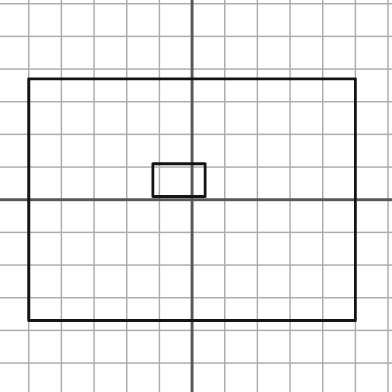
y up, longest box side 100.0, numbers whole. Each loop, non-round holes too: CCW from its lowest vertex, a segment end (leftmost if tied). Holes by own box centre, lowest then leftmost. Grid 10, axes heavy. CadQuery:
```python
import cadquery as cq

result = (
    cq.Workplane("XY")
    .moveTo(-50.0, -37.0)
    .lineTo(50.0, -37.0)
    .lineTo(50.0, 37.0)
    .lineTo(-50.0, 37.0)
    .close()
    .moveTo(-12.0, 1.0)
    .lineTo(4.0, 1.0)
    .lineTo(4.0, 11.0)
    .lineTo(-12.0, 11.0)
    .close()
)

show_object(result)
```